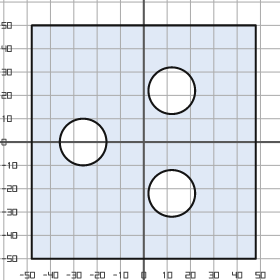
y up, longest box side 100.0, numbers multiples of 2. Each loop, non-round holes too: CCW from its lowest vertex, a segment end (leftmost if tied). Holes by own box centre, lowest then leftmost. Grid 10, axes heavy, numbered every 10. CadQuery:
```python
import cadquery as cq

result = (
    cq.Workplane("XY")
    .moveTo(-48.0, -50.0)
    .lineTo(48.0, -50.0)
    .lineTo(48.0, 50.0)
    .lineTo(-48.0, 50.0)
    .close()
    .moveTo(12.0, -22.0)
    .circle(10.0)
    .moveTo(-26.0, 0.0)
    .circle(10.0)
    .moveTo(12.0, 22.0)
    .circle(10.0)
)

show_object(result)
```